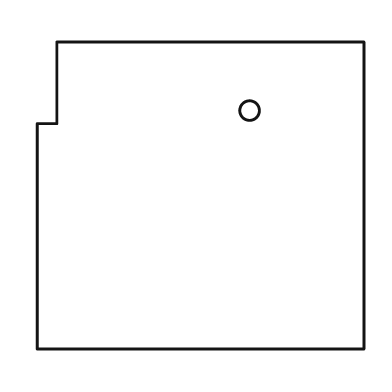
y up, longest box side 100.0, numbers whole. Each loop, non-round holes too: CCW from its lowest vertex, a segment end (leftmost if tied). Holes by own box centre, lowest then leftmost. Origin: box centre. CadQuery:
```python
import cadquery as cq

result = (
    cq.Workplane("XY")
    .moveTo(-50.0, -47.0)
    .lineTo(50.0, -47.0)
    .lineTo(50.0, 47.0)
    .lineTo(-44.0, 47.0)
    .lineTo(-44.0, 22.0)
    .lineTo(-50.0, 22.0)
    .close()
    .moveTo(15.0, 26.0)
    .circle(3.0)
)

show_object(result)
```